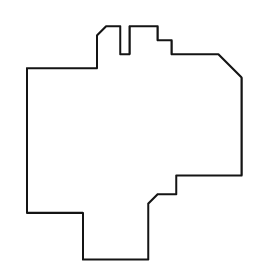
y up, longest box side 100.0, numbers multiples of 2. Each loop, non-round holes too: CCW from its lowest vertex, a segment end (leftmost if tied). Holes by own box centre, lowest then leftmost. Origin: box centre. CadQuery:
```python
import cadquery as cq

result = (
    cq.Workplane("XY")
    .moveTo(-22.0, -50.0)
    .lineTo(6.0, -50.0)
    .lineTo(6.0, -26.0)
    .lineTo(10.0, -22.0)
    .lineTo(18.0, -22.0)
    .lineTo(18.0, -14.0)
    .lineTo(46.0, -14.0)
    .lineTo(46.0, 28.0)
    .lineTo(36.0, 38.0)
    .lineTo(16.0, 38.0)
    .lineTo(16.0, 44.0)
    .lineTo(10.0, 44.0)
    .lineTo(10.0, 50.0)
    .lineTo(-2.0, 50.0)
    .lineTo(-2.0, 38.0)
    .lineTo(-6.0, 38.0)
    .lineTo(-6.0, 50.0)
    .lineTo(-12.0, 50.0)
    .lineTo(-16.0, 46.0)
    .lineTo(-16.0, 32.0)
    .lineTo(-46.0, 32.0)
    .lineTo(-46.0, -30.0)
    .lineTo(-22.0, -30.0)
    .close()
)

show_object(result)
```